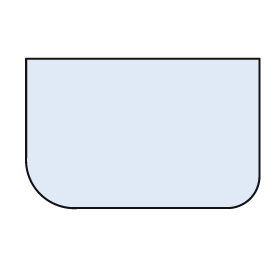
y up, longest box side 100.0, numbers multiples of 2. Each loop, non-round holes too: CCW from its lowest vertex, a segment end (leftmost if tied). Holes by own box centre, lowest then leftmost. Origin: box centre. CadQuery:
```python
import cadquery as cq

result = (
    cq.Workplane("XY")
    .moveTo(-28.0, -32.0)
    .lineTo(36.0, -32.0)
    .threePointArc((46.0, -28.0), (50.0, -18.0))
    .lineTo(50.0, 32.0)
    .lineTo(-50.0, 32.0)
    .lineTo(-50.0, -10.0)
    .threePointArc((-44.0, -26.0), (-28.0, -32.0))
    .close()
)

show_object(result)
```